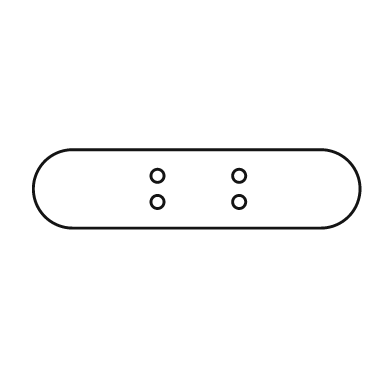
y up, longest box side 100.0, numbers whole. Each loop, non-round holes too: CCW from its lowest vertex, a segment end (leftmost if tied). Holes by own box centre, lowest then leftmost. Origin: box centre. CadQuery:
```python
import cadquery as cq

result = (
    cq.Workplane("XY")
    .moveTo(-38.0, -12.0)
    .lineTo(38.0, -12.0)
    .threePointArc((50.0, 0.0), (38.0, 12.0))
    .lineTo(-38.0, 12.0)
    .threePointArc((-50.0, 0.0), (-38.0, -12.0))
    .close()
    .moveTo(-12.0, -4.0)
    .circle(2.0)
    .moveTo(13.0, -4.0)
    .circle(2.0)
    .moveTo(-12.0, 4.0)
    .circle(2.0)
    .moveTo(13.0, 4.0)
    .circle(2.0)
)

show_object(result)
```